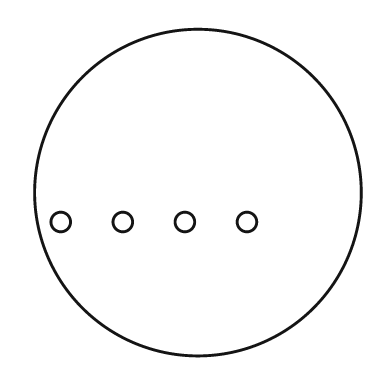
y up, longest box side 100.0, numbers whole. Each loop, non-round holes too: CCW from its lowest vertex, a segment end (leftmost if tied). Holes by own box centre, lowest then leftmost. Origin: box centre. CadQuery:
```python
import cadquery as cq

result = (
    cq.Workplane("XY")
    .moveTo(0.0, 0.0)
    .circle(50.0)
    .moveTo(-42.0, -9.0)
    .circle(3.0)
    .moveTo(-23.0, -9.0)
    .circle(3.0)
    .moveTo(-4.0, -9.0)
    .circle(3.0)
    .moveTo(15.0, -9.0)
    .circle(3.0)
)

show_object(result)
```